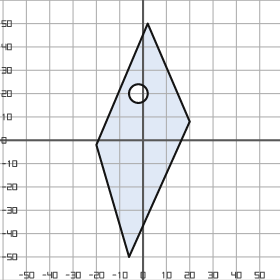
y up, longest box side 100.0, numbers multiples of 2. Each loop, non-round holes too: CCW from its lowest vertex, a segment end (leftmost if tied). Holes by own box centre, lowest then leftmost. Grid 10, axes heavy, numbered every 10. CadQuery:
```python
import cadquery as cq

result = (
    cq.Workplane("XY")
    .moveTo(-6.0, -50.0)
    .lineTo(20.0, 8.0)
    .lineTo(2.0, 50.0)
    .lineTo(-20.0, -2.0)
    .close()
    .moveTo(-2.0, 20.0)
    .circle(4.0)
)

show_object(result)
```